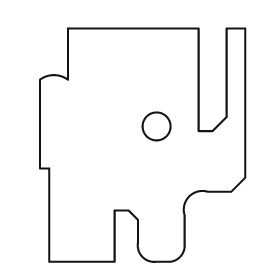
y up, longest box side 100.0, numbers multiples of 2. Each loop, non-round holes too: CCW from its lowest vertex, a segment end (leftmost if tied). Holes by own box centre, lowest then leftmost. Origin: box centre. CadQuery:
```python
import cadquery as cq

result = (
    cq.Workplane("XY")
    .moveTo(-40.0, -50.0)
    .lineTo(-12.0, -50.0)
    .lineTo(-12.0, -28.0)
    .lineTo(-6.0, -28.0)
    .lineTo(-2.0, -32.0)
    .lineTo(-2.0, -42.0)
    .threePointArc((0.0, -48.0), (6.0, -50.0))
    .lineTo(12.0, -50.0)
    .threePointArc((16.0, -48.0), (18.0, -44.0))
    .lineTo(18.0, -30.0)
    .threePointArc((20.0, -22.0), (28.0, -20.0))
    .lineTo(38.0, -20.0)
    .lineTo(44.0, -14.0)
    .lineTo(44.0, 50.0)
    .lineTo(36.0, 50.0)
    .lineTo(36.0, 12.0)
    .lineTo(30.0, 6.0)
    .lineTo(24.0, 6.0)
    .lineTo(24.0, 50.0)
    .lineTo(-32.0, 50.0)
    .lineTo(-32.0, 28.0)
    .threePointArc((-38.0, 30.0), (-44.0, 28.0))
    .lineTo(-44.0, -10.0)
    .lineTo(-40.0, -10.0)
    .close()
    .moveTo(6.0, 8.0)
    .circle(6.0)
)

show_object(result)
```